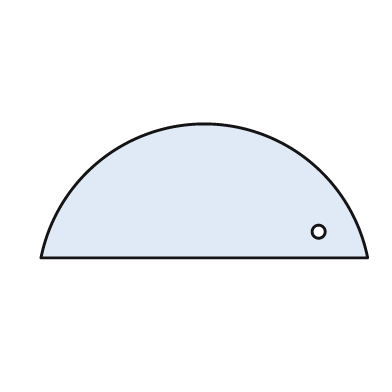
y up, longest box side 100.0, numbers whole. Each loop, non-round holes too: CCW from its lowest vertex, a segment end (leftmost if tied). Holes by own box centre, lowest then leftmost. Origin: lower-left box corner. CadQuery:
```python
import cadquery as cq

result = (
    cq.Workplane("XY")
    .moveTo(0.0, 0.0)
    .lineTo(100.0, 0.0)
    .threePointArc((50.0, 41.0), (0.0, 0.0))
    .close()
    .moveTo(85.0, 8.0)
    .circle(2.0)
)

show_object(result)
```